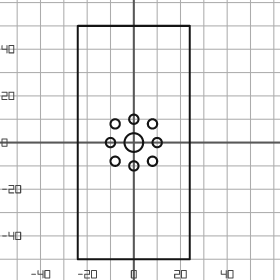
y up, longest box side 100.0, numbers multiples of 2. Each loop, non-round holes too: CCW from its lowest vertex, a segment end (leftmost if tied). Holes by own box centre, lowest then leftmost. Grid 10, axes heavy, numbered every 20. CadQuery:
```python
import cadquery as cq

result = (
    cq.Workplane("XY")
    .moveTo(-24.0, -50.0)
    .lineTo(24.0, -50.0)
    .lineTo(24.0, 50.0)
    .lineTo(-24.0, 50.0)
    .close()
    .moveTo(0.0, -10.0)
    .circle(2.0)
    .moveTo(-8.0, -8.0)
    .circle(2.0)
    .moveTo(8.0, -8.0)
    .circle(2.0)
    .moveTo(-10.0, 0.0)
    .circle(2.0)
    .moveTo(0.0, 0.0)
    .circle(4.0)
    .moveTo(10.0, 0.0)
    .circle(2.0)
    .moveTo(-8.0, 8.0)
    .circle(2.0)
    .moveTo(8.0, 8.0)
    .circle(2.0)
    .moveTo(0.0, 10.0)
    .circle(2.0)
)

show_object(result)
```